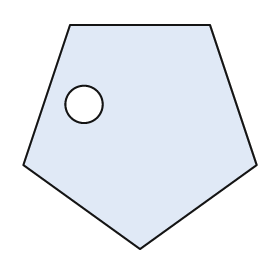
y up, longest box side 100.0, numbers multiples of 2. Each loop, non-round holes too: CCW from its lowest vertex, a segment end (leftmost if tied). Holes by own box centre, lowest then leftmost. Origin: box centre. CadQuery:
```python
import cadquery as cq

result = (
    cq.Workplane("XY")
    .moveTo(0.0, -48.0)
    .lineTo(50.0, -12.0)
    .lineTo(30.0, 48.0)
    .lineTo(-30.0, 48.0)
    .lineTo(-50.0, -12.0)
    .close()
    .moveTo(-24.0, 14.0)
    .circle(8.0)
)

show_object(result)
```